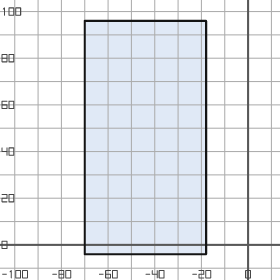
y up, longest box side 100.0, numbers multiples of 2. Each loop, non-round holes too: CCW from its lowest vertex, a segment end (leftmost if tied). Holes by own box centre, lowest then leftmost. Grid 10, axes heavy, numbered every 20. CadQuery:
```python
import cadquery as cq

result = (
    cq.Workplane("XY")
    .moveTo(-70.0, -4.0)
    .lineTo(-18.0, -4.0)
    .lineTo(-18.0, 96.0)
    .lineTo(-70.0, 96.0)
    .close()
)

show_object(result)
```